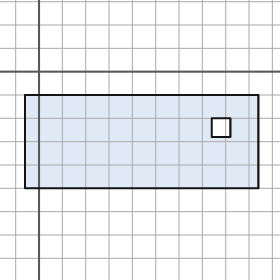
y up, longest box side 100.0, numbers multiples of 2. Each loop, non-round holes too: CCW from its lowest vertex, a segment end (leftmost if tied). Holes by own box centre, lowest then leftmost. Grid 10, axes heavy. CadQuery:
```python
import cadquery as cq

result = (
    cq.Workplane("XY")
    .moveTo(-6.0, -50.0)
    .lineTo(94.0, -50.0)
    .lineTo(94.0, -10.0)
    .lineTo(-6.0, -10.0)
    .close()
    .moveTo(74.0, -28.0)
    .lineTo(82.0, -28.0)
    .lineTo(82.0, -20.0)
    .lineTo(74.0, -20.0)
    .close()
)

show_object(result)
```